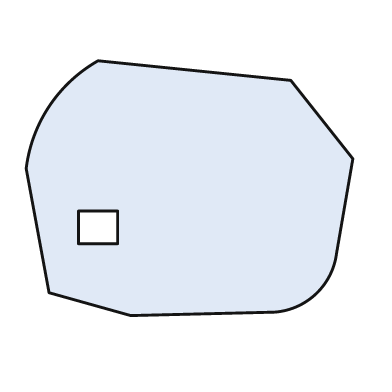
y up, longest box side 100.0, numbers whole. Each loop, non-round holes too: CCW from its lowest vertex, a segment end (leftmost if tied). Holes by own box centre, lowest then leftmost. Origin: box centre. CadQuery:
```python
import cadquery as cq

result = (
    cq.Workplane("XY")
    .moveTo(-18.0, -39.0)
    .lineTo(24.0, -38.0)
    .threePointArc((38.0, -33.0), (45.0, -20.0))
    .lineTo(50.0, 9.0)
    .lineTo(31.0, 33.0)
    .lineTo(-28.0, 39.0)
    .threePointArc((-43.0, 25.0), (-50.0, 6.0))
    .lineTo(-43.0, -32.0)
    .close()
    .moveTo(-34.0, -17.0)
    .lineTo(-22.0, -17.0)
    .lineTo(-22.0, -7.0)
    .lineTo(-34.0, -7.0)
    .close()
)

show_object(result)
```